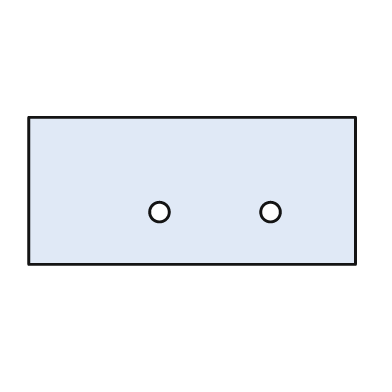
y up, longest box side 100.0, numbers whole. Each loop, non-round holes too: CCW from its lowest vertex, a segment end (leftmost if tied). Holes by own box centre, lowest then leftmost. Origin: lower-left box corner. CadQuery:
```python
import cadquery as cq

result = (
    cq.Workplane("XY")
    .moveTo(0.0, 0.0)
    .lineTo(100.0, 0.0)
    .lineTo(100.0, 45.0)
    .lineTo(0.0, 45.0)
    .close()
    .moveTo(40.0, 16.0)
    .circle(3.0)
    .moveTo(74.0, 16.0)
    .circle(3.0)
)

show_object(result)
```